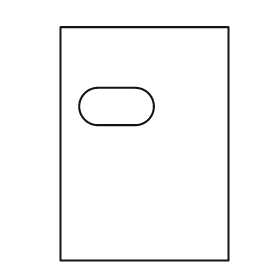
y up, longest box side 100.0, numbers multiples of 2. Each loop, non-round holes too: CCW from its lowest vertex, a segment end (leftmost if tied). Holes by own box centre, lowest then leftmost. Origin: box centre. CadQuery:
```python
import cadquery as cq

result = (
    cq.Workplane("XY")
    .moveTo(-36.0, -50.0)
    .lineTo(36.0, -50.0)
    .lineTo(36.0, 50.0)
    .lineTo(-36.0, 50.0)
    .close()
    .moveTo(-20.0, 8.0)
    .lineTo(-4.0, 8.0)
    .threePointArc((4.0, 16.0), (-4.0, 24.0))
    .lineTo(-20.0, 24.0)
    .threePointArc((-28.0, 16.0), (-20.0, 8.0))
    .close()
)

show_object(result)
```